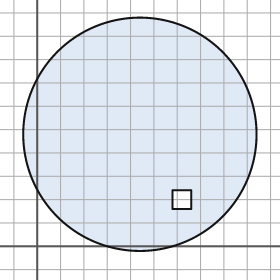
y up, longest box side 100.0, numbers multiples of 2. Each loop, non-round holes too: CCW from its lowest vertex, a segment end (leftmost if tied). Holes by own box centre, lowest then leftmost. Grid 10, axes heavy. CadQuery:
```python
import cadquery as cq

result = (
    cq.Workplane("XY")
    .moveTo(44.0, 48.0)
    .circle(50.0)
    .moveTo(58.0, 16.0)
    .lineTo(66.0, 16.0)
    .lineTo(66.0, 24.0)
    .lineTo(58.0, 24.0)
    .close()
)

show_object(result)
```